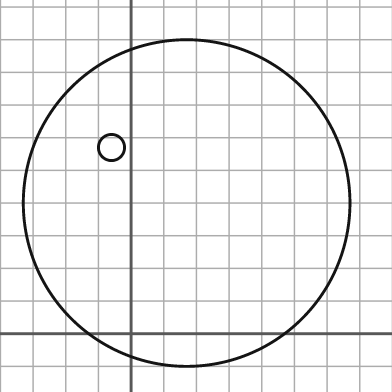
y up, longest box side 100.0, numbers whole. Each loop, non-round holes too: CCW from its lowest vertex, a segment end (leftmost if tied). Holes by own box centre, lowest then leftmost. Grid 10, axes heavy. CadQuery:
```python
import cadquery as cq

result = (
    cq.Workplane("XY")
    .moveTo(17.0, 40.0)
    .circle(50.0)
    .moveTo(-6.0, 57.0)
    .circle(4.0)
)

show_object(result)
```